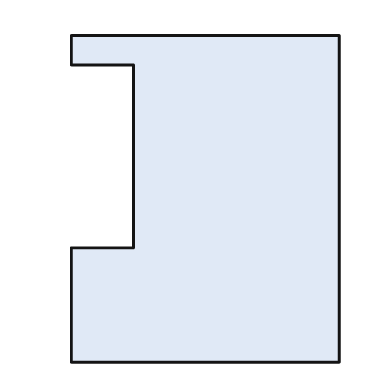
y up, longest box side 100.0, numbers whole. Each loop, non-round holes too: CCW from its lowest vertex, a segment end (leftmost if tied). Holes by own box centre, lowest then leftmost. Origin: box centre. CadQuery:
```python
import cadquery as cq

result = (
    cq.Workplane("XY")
    .moveTo(-41.0, -50.0)
    .lineTo(41.0, -50.0)
    .lineTo(41.0, 50.0)
    .lineTo(-41.0, 50.0)
    .lineTo(-41.0, 41.0)
    .lineTo(-22.0, 41.0)
    .lineTo(-22.0, -15.0)
    .lineTo(-41.0, -15.0)
    .close()
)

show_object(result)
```